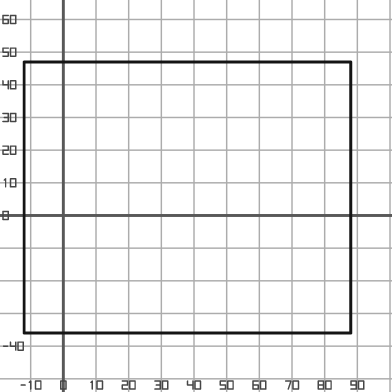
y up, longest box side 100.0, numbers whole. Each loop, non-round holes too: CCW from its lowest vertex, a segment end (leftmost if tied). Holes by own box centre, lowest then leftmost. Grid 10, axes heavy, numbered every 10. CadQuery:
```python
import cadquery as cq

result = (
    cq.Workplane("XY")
    .moveTo(-12.0, -36.0)
    .lineTo(88.0, -36.0)
    .lineTo(88.0, 47.0)
    .lineTo(-12.0, 47.0)
    .close()
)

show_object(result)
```